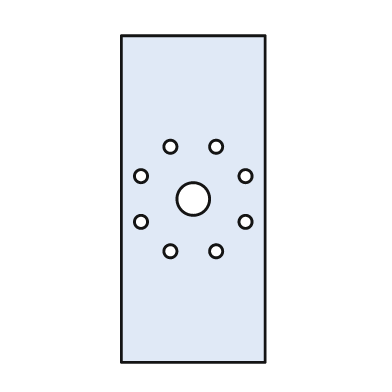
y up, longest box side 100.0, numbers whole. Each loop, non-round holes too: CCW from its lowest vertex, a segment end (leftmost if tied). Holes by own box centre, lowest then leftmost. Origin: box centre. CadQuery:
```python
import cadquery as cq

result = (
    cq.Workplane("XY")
    .moveTo(-22.0, -50.0)
    .lineTo(22.0, -50.0)
    .lineTo(22.0, 50.0)
    .lineTo(-22.0, 50.0)
    .close()
    .moveTo(-7.0, -16.0)
    .circle(2.0)
    .moveTo(7.0, -16.0)
    .circle(2.0)
    .moveTo(-16.0, -7.0)
    .circle(2.0)
    .moveTo(16.0, -7.0)
    .circle(2.0)
    .moveTo(0.0, 0.0)
    .circle(5.0)
    .moveTo(-16.0, 7.0)
    .circle(2.0)
    .moveTo(16.0, 7.0)
    .circle(2.0)
    .moveTo(-7.0, 16.0)
    .circle(2.0)
    .moveTo(7.0, 16.0)
    .circle(2.0)
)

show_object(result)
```